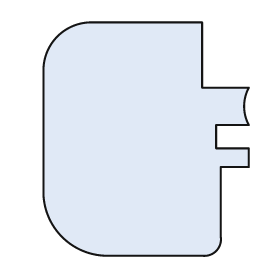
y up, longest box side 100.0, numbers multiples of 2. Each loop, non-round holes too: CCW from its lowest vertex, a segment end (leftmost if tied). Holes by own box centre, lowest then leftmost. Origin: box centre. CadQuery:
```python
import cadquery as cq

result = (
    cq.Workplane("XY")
    .moveTo(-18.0, -50.0)
    .lineTo(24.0, -50.0)
    .threePointArc((30.0, -48.0), (32.0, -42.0))
    .lineTo(32.0, -12.0)
    .lineTo(44.0, -12.0)
    .lineTo(44.0, -4.0)
    .lineTo(30.0, -4.0)
    .lineTo(30.0, 6.0)
    .lineTo(44.0, 6.0)
    .threePointArc((42.0, 14.0), (44.0, 22.0))
    .lineTo(24.0, 22.0)
    .lineTo(24.0, 50.0)
    .lineTo(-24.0, 50.0)
    .threePointArc((-38.0, 44.0), (-44.0, 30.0))
    .lineTo(-44.0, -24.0)
    .threePointArc((-36.0, -42.0), (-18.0, -50.0))
    .close()
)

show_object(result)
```